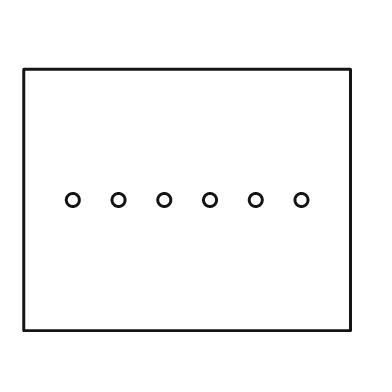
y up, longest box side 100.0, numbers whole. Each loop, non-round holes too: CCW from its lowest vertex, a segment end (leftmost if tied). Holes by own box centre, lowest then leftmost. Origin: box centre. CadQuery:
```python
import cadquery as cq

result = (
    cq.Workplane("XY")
    .moveTo(-50.0, -40.0)
    .lineTo(50.0, -40.0)
    .lineTo(50.0, 40.0)
    .lineTo(-50.0, 40.0)
    .close()
    .moveTo(-35.0, 0.0)
    .circle(2.0)
    .moveTo(-21.0, 0.0)
    .circle(2.0)
    .moveTo(-7.0, 0.0)
    .circle(2.0)
    .moveTo(7.0, 0.0)
    .circle(2.0)
    .moveTo(21.0, 0.0)
    .circle(2.0)
    .moveTo(35.0, 0.0)
    .circle(2.0)
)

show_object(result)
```